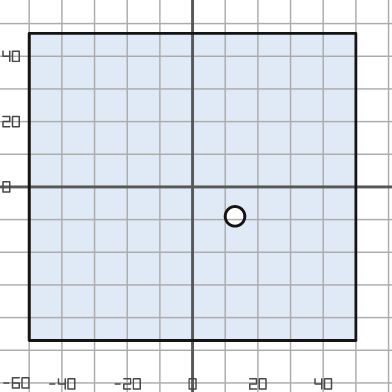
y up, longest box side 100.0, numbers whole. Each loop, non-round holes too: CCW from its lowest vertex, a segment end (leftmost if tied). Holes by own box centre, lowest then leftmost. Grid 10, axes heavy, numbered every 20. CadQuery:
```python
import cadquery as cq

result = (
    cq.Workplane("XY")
    .moveTo(-50.0, -47.0)
    .lineTo(50.0, -47.0)
    .lineTo(50.0, 47.0)
    .lineTo(-50.0, 47.0)
    .close()
    .moveTo(13.0, -9.0)
    .circle(3.0)
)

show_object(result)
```